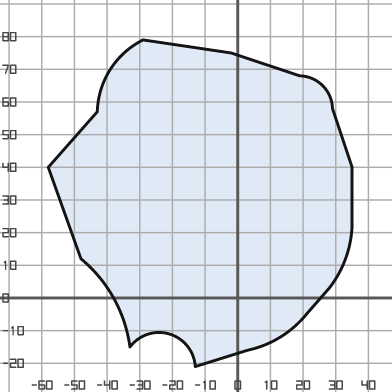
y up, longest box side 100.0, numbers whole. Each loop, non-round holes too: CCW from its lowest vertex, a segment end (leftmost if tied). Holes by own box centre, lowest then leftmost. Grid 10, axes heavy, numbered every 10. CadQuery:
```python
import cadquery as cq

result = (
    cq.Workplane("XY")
    .moveTo(-13.0, -21.0)
    .lineTo(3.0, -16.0)
    .threePointArc((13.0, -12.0), (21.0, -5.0))
    .lineTo(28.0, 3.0)
    .threePointArc((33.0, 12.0), (35.0, 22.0))
    .lineTo(35.0, 40.0)
    .lineTo(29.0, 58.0)
    .threePointArc((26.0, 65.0), (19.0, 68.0))
    .lineTo(-2.0, 75.0)
    .lineTo(-29.0, 79.0)
    .threePointArc((-39.0, 70.0), (-43.0, 57.0))
    .lineTo(-58.0, 40.0)
    .lineTo(-48.0, 12.0)
    .threePointArc((-38.0, 0.0), (-33.0, -15.0))
    .threePointArc((-21.0, -11.0), (-13.0, -21.0))
    .close()
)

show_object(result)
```